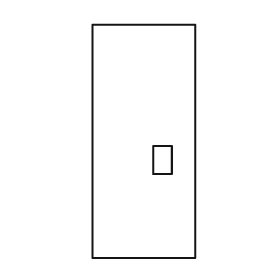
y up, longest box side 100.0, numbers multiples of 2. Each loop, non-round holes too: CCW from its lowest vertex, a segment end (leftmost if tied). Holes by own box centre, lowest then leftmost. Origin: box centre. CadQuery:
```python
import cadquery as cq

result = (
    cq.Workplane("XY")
    .moveTo(-22.0, -50.0)
    .lineTo(22.0, -50.0)
    .lineTo(22.0, 50.0)
    .lineTo(-22.0, 50.0)
    .close()
    .moveTo(4.0, -14.0)
    .lineTo(12.0, -14.0)
    .lineTo(12.0, -2.0)
    .lineTo(4.0, -2.0)
    .close()
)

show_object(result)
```